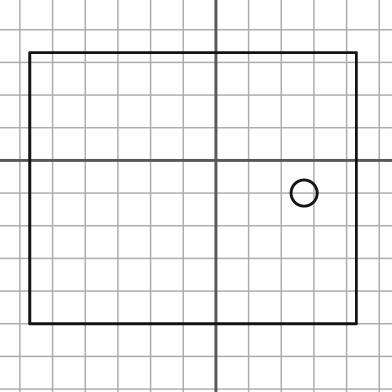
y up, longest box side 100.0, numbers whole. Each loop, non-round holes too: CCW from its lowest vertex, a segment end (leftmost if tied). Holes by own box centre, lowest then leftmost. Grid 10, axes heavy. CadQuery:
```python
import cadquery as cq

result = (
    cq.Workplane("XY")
    .moveTo(-57.0, -50.0)
    .lineTo(43.0, -50.0)
    .lineTo(43.0, 33.0)
    .lineTo(-57.0, 33.0)
    .close()
    .moveTo(27.0, -10.0)
    .circle(4.0)
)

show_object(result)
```